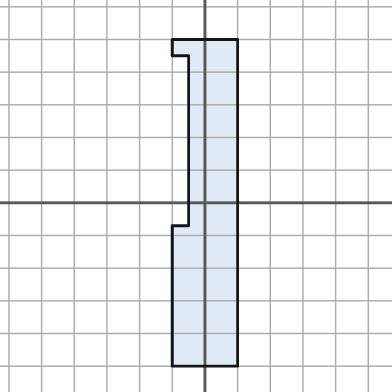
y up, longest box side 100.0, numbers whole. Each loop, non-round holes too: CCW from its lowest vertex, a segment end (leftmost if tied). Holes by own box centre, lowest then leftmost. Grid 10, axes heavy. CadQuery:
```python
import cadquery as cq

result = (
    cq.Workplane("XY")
    .moveTo(-10.0, -50.0)
    .lineTo(10.0, -50.0)
    .lineTo(10.0, 50.0)
    .lineTo(-10.0, 50.0)
    .lineTo(-10.0, 45.0)
    .lineTo(-5.0, 45.0)
    .lineTo(-5.0, -7.0)
    .lineTo(-10.0, -7.0)
    .close()
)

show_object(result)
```